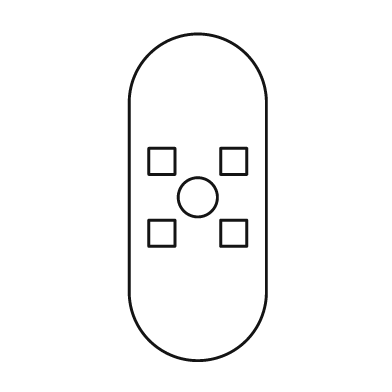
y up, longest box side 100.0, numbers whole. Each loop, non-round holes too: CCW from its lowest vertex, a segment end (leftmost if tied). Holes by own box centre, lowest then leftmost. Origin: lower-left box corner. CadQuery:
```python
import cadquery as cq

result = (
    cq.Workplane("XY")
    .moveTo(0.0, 21.0)
    .threePointArc((21.0, 0.0), (42.0, 21.0))
    .lineTo(42.0, 79.0)
    .threePointArc((21.0, 100.0), (0.0, 79.0))
    .close()
    .moveTo(6.0, 35.0)
    .lineTo(14.0, 35.0)
    .lineTo(14.0, 43.0)
    .lineTo(6.0, 43.0)
    .close()
    .moveTo(28.0, 35.0)
    .lineTo(36.0, 35.0)
    .lineTo(36.0, 43.0)
    .lineTo(28.0, 43.0)
    .close()
    .moveTo(21.0, 50.0)
    .circle(6.0)
    .moveTo(6.0, 57.0)
    .lineTo(14.0, 57.0)
    .lineTo(14.0, 65.0)
    .lineTo(6.0, 65.0)
    .close()
    .moveTo(28.0, 57.0)
    .lineTo(36.0, 57.0)
    .lineTo(36.0, 65.0)
    .lineTo(28.0, 65.0)
    .close()
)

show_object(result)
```